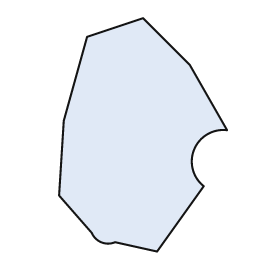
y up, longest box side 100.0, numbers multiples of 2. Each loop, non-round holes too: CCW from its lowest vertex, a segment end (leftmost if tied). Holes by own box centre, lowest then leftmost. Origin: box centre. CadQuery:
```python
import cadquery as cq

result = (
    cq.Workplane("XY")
    .moveTo(6.0, -50.0)
    .lineTo(26.0, -22.0)
    .threePointArc((22.0, -6.0), (36.0, 2.0))
    .lineTo(20.0, 30.0)
    .lineTo(0.0, 50.0)
    .lineTo(-24.0, 42.0)
    .lineTo(-34.0, 6.0)
    .lineTo(-36.0, -26.0)
    .lineTo(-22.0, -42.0)
    .threePointArc((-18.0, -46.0), (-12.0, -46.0))
    .close()
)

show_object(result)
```